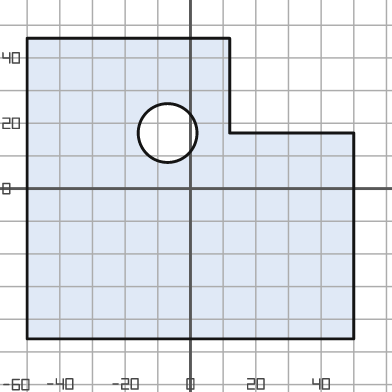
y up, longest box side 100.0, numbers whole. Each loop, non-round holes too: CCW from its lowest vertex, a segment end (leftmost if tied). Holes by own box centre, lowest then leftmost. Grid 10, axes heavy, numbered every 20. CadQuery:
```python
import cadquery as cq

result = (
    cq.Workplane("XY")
    .moveTo(-50.0, -46.0)
    .lineTo(50.0, -46.0)
    .lineTo(50.0, 17.0)
    .lineTo(12.0, 17.0)
    .lineTo(12.0, 46.0)
    .lineTo(-50.0, 46.0)
    .close()
    .moveTo(-7.0, 17.0)
    .circle(9.0)
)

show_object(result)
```